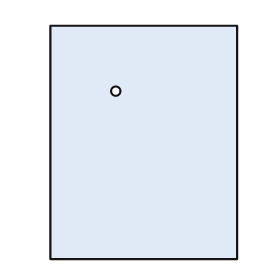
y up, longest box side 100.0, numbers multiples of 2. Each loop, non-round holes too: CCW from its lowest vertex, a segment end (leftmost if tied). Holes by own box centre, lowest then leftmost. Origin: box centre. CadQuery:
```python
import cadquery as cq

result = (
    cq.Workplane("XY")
    .moveTo(-40.0, -50.0)
    .lineTo(40.0, -50.0)
    .lineTo(40.0, 50.0)
    .lineTo(-40.0, 50.0)
    .close()
    .moveTo(-12.0, 22.0)
    .circle(2.0)
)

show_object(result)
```